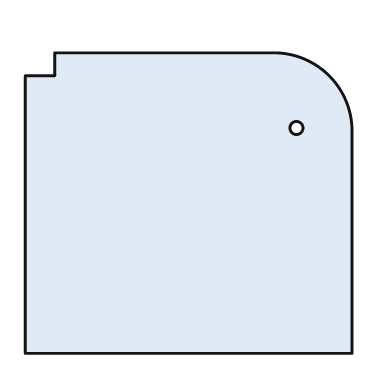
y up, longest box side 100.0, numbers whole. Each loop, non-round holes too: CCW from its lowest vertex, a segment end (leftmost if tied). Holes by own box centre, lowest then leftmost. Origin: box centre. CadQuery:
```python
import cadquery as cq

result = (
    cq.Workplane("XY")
    .moveTo(-50.0, -46.0)
    .lineTo(50.0, -46.0)
    .lineTo(50.0, 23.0)
    .threePointArc((43.0, 39.0), (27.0, 46.0))
    .lineTo(-41.0, 46.0)
    .lineTo(-41.0, 39.0)
    .lineTo(-50.0, 39.0)
    .close()
    .moveTo(33.0, 23.0)
    .circle(2.0)
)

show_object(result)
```